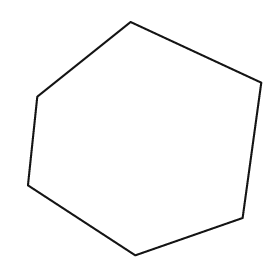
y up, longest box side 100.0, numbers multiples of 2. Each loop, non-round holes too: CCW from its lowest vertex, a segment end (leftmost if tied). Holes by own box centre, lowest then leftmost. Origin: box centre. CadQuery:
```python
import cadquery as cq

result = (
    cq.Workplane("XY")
    .moveTo(-4.0, -50.0)
    .lineTo(42.0, -34.0)
    .lineTo(50.0, 24.0)
    .lineTo(-6.0, 50.0)
    .lineTo(-46.0, 18.0)
    .lineTo(-50.0, -20.0)
    .close()
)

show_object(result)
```